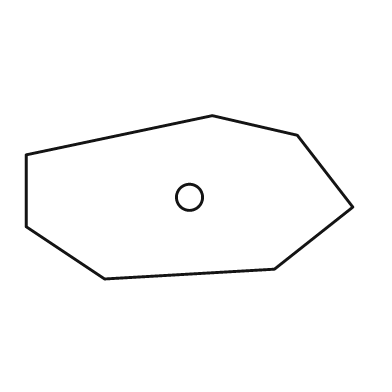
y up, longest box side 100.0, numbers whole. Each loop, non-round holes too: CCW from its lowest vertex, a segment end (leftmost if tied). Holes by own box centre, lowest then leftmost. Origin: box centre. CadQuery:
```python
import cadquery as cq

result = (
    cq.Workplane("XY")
    .moveTo(-26.0, -25.0)
    .lineTo(26.0, -22.0)
    .lineTo(50.0, -3.0)
    .lineTo(33.0, 19.0)
    .lineTo(7.0, 25.0)
    .lineTo(-50.0, 13.0)
    .lineTo(-50.0, -9.0)
    .close()
    .moveTo(0.0, 0.0)
    .circle(4.0)
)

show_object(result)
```